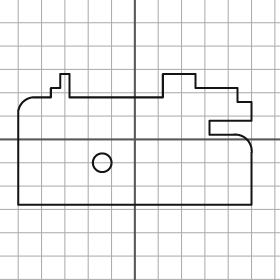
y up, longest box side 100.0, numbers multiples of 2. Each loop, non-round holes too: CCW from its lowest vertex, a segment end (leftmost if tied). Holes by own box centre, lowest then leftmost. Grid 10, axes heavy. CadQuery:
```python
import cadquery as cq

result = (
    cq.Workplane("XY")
    .moveTo(-50.0, -28.0)
    .lineTo(50.0, -28.0)
    .lineTo(50.0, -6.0)
    .threePointArc((48.0, 0.0), (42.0, 2.0))
    .lineTo(32.0, 2.0)
    .lineTo(32.0, 8.0)
    .lineTo(50.0, 8.0)
    .lineTo(50.0, 16.0)
    .lineTo(44.0, 16.0)
    .lineTo(44.0, 22.0)
    .lineTo(26.0, 22.0)
    .lineTo(26.0, 28.0)
    .lineTo(12.0, 28.0)
    .lineTo(12.0, 18.0)
    .lineTo(-28.0, 18.0)
    .lineTo(-28.0, 28.0)
    .lineTo(-32.0, 28.0)
    .lineTo(-32.0, 22.0)
    .lineTo(-36.0, 22.0)
    .lineTo(-36.0, 18.0)
    .lineTo(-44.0, 18.0)
    .threePointArc((-48.0, 16.0), (-50.0, 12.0))
    .close()
    .moveTo(-14.0, -10.0)
    .circle(4.0)
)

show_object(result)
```